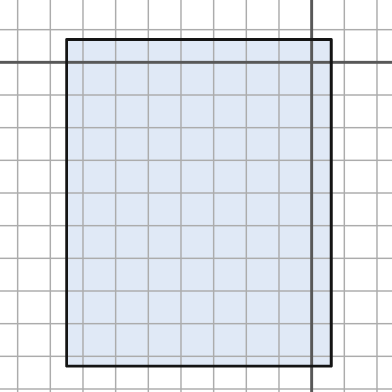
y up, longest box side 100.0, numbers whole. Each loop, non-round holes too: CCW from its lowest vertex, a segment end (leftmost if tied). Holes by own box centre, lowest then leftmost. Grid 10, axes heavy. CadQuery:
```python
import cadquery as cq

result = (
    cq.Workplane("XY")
    .moveTo(-75.0, -93.0)
    .lineTo(6.0, -93.0)
    .lineTo(6.0, 7.0)
    .lineTo(-75.0, 7.0)
    .close()
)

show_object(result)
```